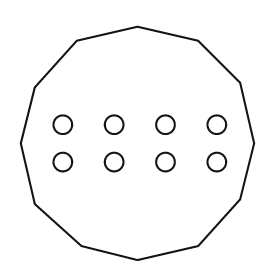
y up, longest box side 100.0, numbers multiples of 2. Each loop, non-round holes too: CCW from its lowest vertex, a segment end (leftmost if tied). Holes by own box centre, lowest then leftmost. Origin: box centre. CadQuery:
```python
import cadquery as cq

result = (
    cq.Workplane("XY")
    .moveTo(0.0, -50.0)
    .lineTo(26.0, -44.0)
    .lineTo(44.0, -24.0)
    .lineTo(50.0, 0.0)
    .lineTo(44.0, 26.0)
    .lineTo(26.0, 44.0)
    .lineTo(0.0, 50.0)
    .lineTo(-26.0, 44.0)
    .lineTo(-44.0, 24.0)
    .lineTo(-50.0, 0.0)
    .lineTo(-44.0, -26.0)
    .lineTo(-24.0, -44.0)
    .close()
    .moveTo(-32.0, -8.0)
    .circle(4.0)
    .moveTo(-10.0, -8.0)
    .circle(4.0)
    .moveTo(12.0, -8.0)
    .circle(4.0)
    .moveTo(34.0, -8.0)
    .circle(4.0)
    .moveTo(-32.0, 8.0)
    .circle(4.0)
    .moveTo(-10.0, 8.0)
    .circle(4.0)
    .moveTo(12.0, 8.0)
    .circle(4.0)
    .moveTo(34.0, 8.0)
    .circle(4.0)
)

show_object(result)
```